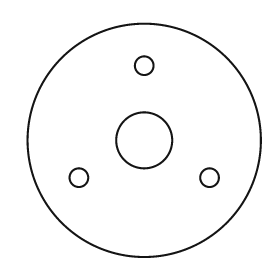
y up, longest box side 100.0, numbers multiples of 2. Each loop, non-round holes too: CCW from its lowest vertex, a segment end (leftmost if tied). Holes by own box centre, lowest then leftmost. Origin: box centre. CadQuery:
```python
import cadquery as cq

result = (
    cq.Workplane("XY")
    .moveTo(0.0, 0.0)
    .circle(50.0)
    .moveTo(-28.0, -16.0)
    .circle(4.0)
    .moveTo(28.0, -16.0)
    .circle(4.0)
    .moveTo(0.0, 0.0)
    .circle(12.0)
    .moveTo(0.0, 32.0)
    .circle(4.0)
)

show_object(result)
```